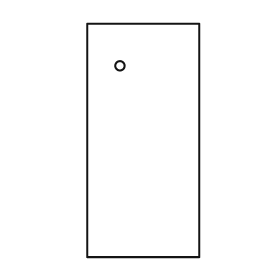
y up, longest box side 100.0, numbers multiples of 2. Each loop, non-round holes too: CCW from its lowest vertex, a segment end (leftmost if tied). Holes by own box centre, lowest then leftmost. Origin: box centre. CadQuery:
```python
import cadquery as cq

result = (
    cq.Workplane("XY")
    .moveTo(-24.0, -50.0)
    .lineTo(24.0, -50.0)
    .lineTo(24.0, 50.0)
    .lineTo(-24.0, 50.0)
    .close()
    .moveTo(-10.0, 32.0)
    .circle(2.0)
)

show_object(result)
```